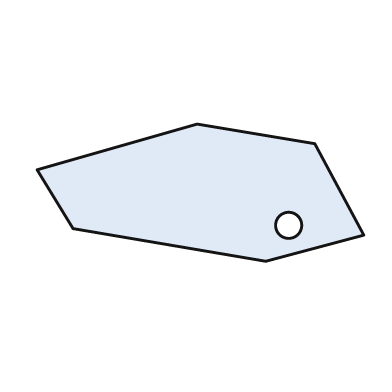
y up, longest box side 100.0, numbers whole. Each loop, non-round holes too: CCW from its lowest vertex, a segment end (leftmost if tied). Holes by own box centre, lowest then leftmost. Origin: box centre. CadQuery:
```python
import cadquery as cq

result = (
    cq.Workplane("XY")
    .moveTo(20.0, -21.0)
    .lineTo(50.0, -13.0)
    .lineTo(35.0, 15.0)
    .lineTo(-1.0, 21.0)
    .lineTo(-50.0, 7.0)
    .lineTo(-39.0, -11.0)
    .close()
    .moveTo(27.0, -10.0)
    .circle(4.0)
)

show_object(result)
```